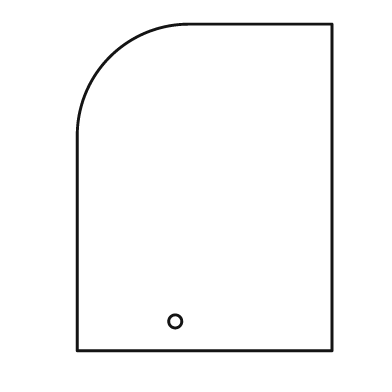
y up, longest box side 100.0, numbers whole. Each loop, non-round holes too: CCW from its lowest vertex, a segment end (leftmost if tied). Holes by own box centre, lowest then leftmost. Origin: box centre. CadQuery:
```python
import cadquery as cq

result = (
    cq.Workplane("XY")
    .moveTo(-39.0, -50.0)
    .lineTo(39.0, -50.0)
    .lineTo(39.0, 50.0)
    .lineTo(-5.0, 50.0)
    .threePointArc((-29.0, 40.0), (-39.0, 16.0))
    .close()
    .moveTo(-9.0, -41.0)
    .circle(2.0)
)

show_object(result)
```